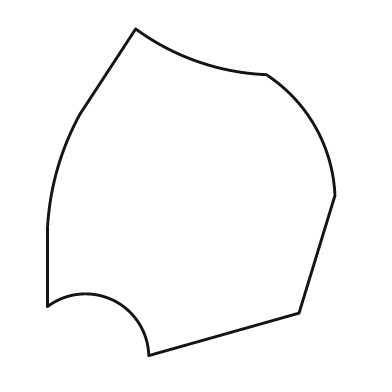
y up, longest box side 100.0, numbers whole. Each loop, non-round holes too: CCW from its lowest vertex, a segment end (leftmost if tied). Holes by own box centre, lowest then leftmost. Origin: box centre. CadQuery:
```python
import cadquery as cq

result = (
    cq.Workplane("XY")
    .moveTo(-13.0, -50.0)
    .lineTo(33.0, -37.0)
    .lineTo(44.0, -1.0)
    .threePointArc((38.0, 20.0), (23.0, 36.0))
    .threePointArc((2.0, 40.0), (-17.0, 50.0))
    .lineTo(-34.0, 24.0)
    .threePointArc((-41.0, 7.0), (-44.0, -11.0))
    .lineTo(-44.0, -35.0)
    .threePointArc((-24.0, -33.0), (-13.0, -50.0))
    .close()
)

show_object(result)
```